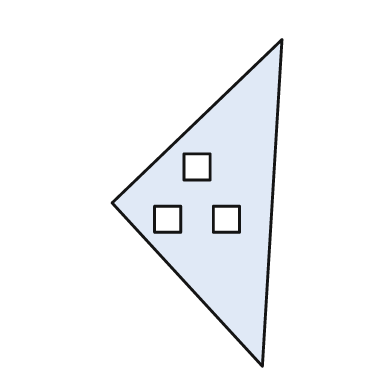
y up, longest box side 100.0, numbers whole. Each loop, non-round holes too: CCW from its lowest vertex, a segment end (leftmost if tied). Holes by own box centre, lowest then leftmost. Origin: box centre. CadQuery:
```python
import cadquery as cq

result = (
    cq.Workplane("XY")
    .moveTo(20.0, -50.0)
    .lineTo(26.0, 50.0)
    .lineTo(-26.0, 0.0)
    .close()
    .moveTo(-13.0, -9.0)
    .lineTo(-5.0, -9.0)
    .lineTo(-5.0, -1.0)
    .lineTo(-13.0, -1.0)
    .close()
    .moveTo(5.0, -9.0)
    .lineTo(13.0, -9.0)
    .lineTo(13.0, -1.0)
    .lineTo(5.0, -1.0)
    .close()
    .moveTo(-4.0, 7.0)
    .lineTo(4.0, 7.0)
    .lineTo(4.0, 15.0)
    .lineTo(-4.0, 15.0)
    .close()
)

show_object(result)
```